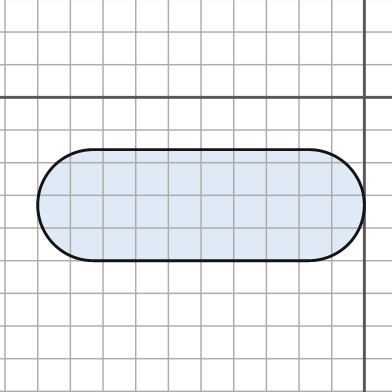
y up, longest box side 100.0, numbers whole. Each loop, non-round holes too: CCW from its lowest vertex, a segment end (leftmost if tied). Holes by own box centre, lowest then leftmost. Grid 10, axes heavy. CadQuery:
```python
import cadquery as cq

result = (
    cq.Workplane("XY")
    .moveTo(-83.0, -50.0)
    .lineTo(-17.0, -50.0)
    .threePointArc((0.0, -33.0), (-17.0, -16.0))
    .lineTo(-83.0, -16.0)
    .threePointArc((-100.0, -33.0), (-83.0, -50.0))
    .close()
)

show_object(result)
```